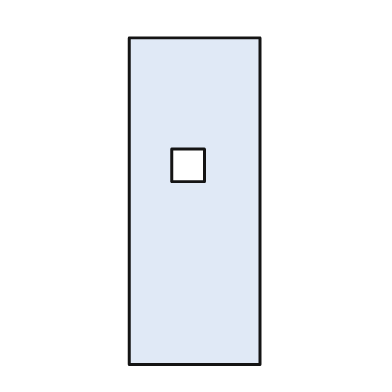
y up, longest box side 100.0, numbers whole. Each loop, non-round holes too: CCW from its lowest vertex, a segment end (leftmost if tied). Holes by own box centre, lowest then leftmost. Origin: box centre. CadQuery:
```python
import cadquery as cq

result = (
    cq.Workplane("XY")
    .moveTo(-20.0, -50.0)
    .lineTo(20.0, -50.0)
    .lineTo(20.0, 50.0)
    .lineTo(-20.0, 50.0)
    .close()
    .moveTo(-7.0, 6.0)
    .lineTo(3.0, 6.0)
    .lineTo(3.0, 16.0)
    .lineTo(-7.0, 16.0)
    .close()
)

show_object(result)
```